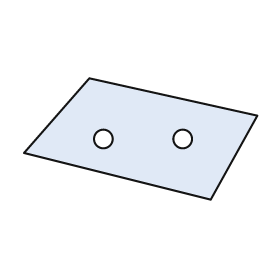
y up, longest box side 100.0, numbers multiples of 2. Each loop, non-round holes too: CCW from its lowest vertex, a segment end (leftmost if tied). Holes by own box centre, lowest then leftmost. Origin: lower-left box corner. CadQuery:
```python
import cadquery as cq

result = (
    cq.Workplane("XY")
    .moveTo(80.0, 0.0)
    .lineTo(100.0, 36.0)
    .lineTo(28.0, 52.0)
    .lineTo(0.0, 20.0)
    .close()
    .moveTo(34.0, 26.0)
    .circle(4.0)
    .moveTo(68.0, 26.0)
    .circle(4.0)
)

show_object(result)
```